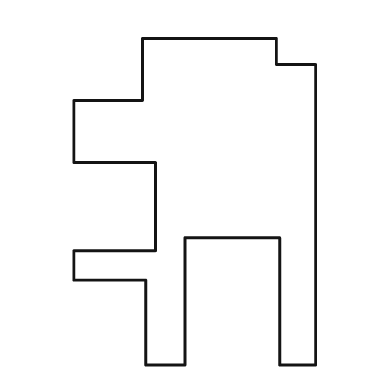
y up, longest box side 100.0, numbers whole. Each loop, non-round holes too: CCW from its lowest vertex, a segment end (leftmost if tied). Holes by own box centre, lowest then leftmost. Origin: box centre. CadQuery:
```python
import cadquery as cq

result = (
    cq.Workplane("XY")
    .moveTo(-15.0, -50.0)
    .lineTo(-3.0, -50.0)
    .lineTo(-3.0, -11.0)
    .lineTo(26.0, -11.0)
    .lineTo(26.0, -50.0)
    .lineTo(37.0, -50.0)
    .lineTo(37.0, 42.0)
    .lineTo(25.0, 42.0)
    .lineTo(25.0, 50.0)
    .lineTo(-16.0, 50.0)
    .lineTo(-16.0, 31.0)
    .lineTo(-37.0, 31.0)
    .lineTo(-37.0, 12.0)
    .lineTo(-12.0, 12.0)
    .lineTo(-12.0, -15.0)
    .lineTo(-37.0, -15.0)
    .lineTo(-37.0, -24.0)
    .lineTo(-15.0, -24.0)
    .close()
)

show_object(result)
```